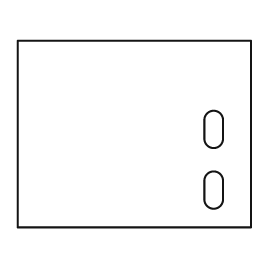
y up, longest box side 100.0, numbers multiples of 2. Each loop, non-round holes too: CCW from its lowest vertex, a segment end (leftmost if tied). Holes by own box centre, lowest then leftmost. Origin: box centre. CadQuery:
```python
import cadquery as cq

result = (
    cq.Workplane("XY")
    .moveTo(-50.0, -40.0)
    .lineTo(50.0, -40.0)
    .lineTo(50.0, 40.0)
    .lineTo(-50.0, 40.0)
    .close()
    .moveTo(30.0, -28.0)
    .threePointArc((34.0, -32.0), (38.0, -28.0))
    .lineTo(38.0, -20.0)
    .threePointArc((34.0, -16.0), (30.0, -20.0))
    .close()
    .moveTo(30.0, -2.0)
    .threePointArc((34.0, -6.0), (38.0, -2.0))
    .lineTo(38.0, 6.0)
    .threePointArc((34.0, 10.0), (30.0, 6.0))
    .close()
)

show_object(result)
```